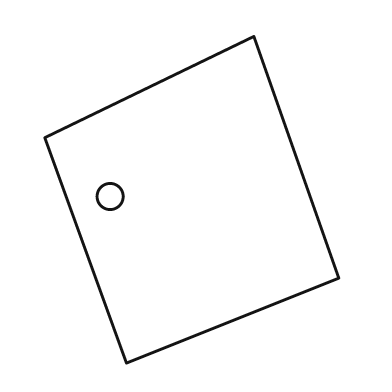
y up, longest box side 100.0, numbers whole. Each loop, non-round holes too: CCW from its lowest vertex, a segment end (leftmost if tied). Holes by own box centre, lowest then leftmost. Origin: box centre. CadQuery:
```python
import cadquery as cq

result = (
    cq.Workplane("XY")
    .moveTo(-20.0, -50.0)
    .lineTo(45.0, -24.0)
    .lineTo(19.0, 50.0)
    .lineTo(-45.0, 19.0)
    .close()
    .moveTo(-25.0, 1.0)
    .circle(4.0)
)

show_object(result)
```